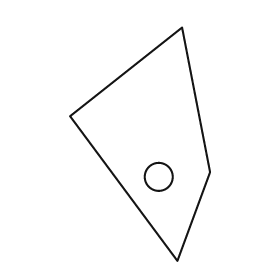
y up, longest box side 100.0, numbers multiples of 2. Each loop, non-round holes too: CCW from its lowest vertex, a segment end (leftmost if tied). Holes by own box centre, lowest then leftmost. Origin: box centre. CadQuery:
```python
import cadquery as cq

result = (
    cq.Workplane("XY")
    .moveTo(16.0, -50.0)
    .lineTo(30.0, -12.0)
    .lineTo(18.0, 50.0)
    .lineTo(-30.0, 12.0)
    .close()
    .moveTo(8.0, -14.0)
    .circle(6.0)
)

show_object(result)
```